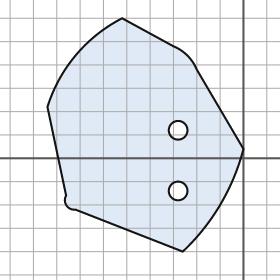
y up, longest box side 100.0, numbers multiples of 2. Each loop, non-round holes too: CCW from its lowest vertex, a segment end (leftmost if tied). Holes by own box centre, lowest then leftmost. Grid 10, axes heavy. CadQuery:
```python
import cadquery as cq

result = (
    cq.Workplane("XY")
    .moveTo(-26.0, -40.0)
    .threePointArc((-10.0, -20.0), (0.0, 4.0))
    .lineTo(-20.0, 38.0)
    .threePointArc((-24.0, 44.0), (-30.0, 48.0))
    .lineTo(-52.0, 60.0)
    .threePointArc((-72.0, 44.0), (-84.0, 22.0))
    .lineTo(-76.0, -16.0)
    .threePointArc((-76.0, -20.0), (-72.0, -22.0))
    .close()
    .moveTo(-28.0, -14.0)
    .circle(4.0)
    .moveTo(-28.0, 12.0)
    .circle(4.0)
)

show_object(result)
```